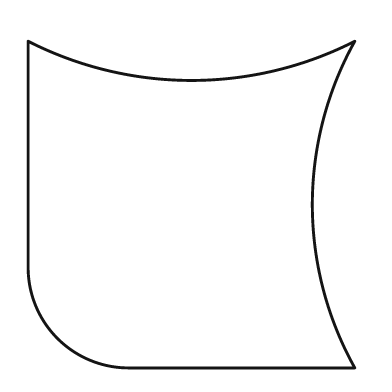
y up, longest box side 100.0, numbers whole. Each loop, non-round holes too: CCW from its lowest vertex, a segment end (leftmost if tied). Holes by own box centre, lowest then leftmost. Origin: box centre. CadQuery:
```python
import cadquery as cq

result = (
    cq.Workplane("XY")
    .moveTo(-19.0, -50.0)
    .lineTo(50.0, -50.0)
    .threePointArc((37.0, 0.0), (50.0, 50.0))
    .threePointArc((0.0, 38.0), (-50.0, 50.0))
    .lineTo(-50.0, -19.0)
    .threePointArc((-41.0, -41.0), (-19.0, -50.0))
    .close()
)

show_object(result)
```